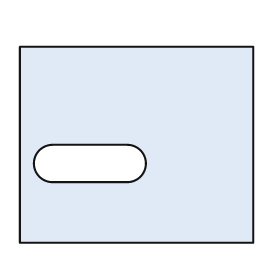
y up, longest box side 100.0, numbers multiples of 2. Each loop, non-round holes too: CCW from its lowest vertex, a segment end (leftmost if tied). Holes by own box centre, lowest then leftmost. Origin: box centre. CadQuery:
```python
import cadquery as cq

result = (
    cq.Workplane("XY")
    .moveTo(-50.0, -42.0)
    .lineTo(50.0, -42.0)
    .lineTo(50.0, 42.0)
    .lineTo(-50.0, 42.0)
    .close()
    .moveTo(-36.0, -16.0)
    .lineTo(-4.0, -16.0)
    .threePointArc((4.0, -8.0), (-4.0, 0.0))
    .lineTo(-36.0, 0.0)
    .threePointArc((-44.0, -8.0), (-36.0, -16.0))
    .close()
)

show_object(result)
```